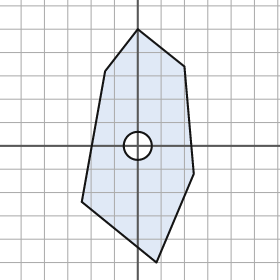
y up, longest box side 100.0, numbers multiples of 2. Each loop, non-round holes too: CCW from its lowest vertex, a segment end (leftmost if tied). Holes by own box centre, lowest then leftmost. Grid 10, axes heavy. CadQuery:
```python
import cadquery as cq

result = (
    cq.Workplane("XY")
    .moveTo(8.0, -50.0)
    .lineTo(24.0, -12.0)
    .lineTo(20.0, 34.0)
    .lineTo(0.0, 50.0)
    .lineTo(-14.0, 32.0)
    .lineTo(-24.0, -24.0)
    .close()
    .moveTo(0.0, 0.0)
    .circle(6.0)
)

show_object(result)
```